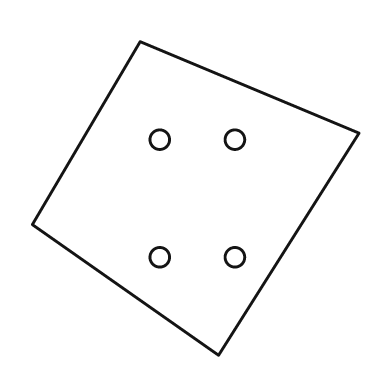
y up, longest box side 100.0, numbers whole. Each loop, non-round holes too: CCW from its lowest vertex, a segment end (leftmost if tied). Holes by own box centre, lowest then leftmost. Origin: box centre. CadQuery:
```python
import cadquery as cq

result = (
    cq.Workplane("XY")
    .moveTo(7.0, -48.0)
    .lineTo(50.0, 20.0)
    .lineTo(-17.0, 48.0)
    .lineTo(-50.0, -8.0)
    .close()
    .moveTo(-11.0, -18.0)
    .circle(3.0)
    .moveTo(12.0, -18.0)
    .circle(3.0)
    .moveTo(-11.0, 18.0)
    .circle(3.0)
    .moveTo(12.0, 18.0)
    .circle(3.0)
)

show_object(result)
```